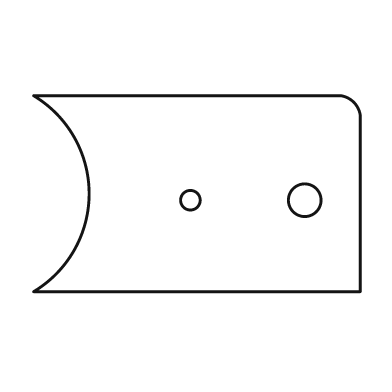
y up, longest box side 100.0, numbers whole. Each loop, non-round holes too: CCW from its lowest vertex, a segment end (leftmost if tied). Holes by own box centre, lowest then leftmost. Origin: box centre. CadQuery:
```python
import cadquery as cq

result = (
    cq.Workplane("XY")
    .moveTo(-50.0, -30.0)
    .lineTo(50.0, -30.0)
    .lineTo(50.0, 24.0)
    .threePointArc((48.0, 28.0), (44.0, 30.0))
    .lineTo(-50.0, 30.0)
    .threePointArc((-33.0, 0.0), (-50.0, -30.0))
    .close()
    .moveTo(-2.0, -2.0)
    .circle(3.0)
    .moveTo(33.0, -2.0)
    .circle(5.0)
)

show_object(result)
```